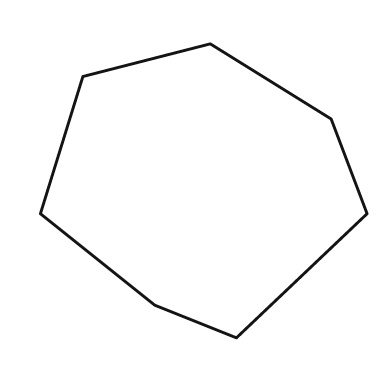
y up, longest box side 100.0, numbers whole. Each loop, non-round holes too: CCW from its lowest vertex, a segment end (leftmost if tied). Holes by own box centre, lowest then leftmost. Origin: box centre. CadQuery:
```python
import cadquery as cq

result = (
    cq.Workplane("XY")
    .moveTo(10.0, -45.0)
    .lineTo(50.0, -7.0)
    .lineTo(39.0, 22.0)
    .lineTo(2.0, 45.0)
    .lineTo(-37.0, 35.0)
    .lineTo(-50.0, -7.0)
    .lineTo(-15.0, -35.0)
    .close()
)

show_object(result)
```